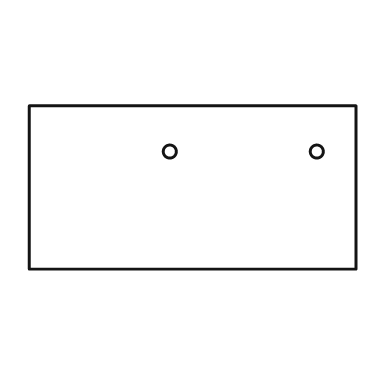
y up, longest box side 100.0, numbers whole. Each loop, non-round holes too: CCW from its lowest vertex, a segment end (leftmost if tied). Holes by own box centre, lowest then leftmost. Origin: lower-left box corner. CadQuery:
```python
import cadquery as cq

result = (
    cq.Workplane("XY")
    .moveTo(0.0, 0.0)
    .lineTo(100.0, 0.0)
    .lineTo(100.0, 50.0)
    .lineTo(0.0, 50.0)
    .close()
    .moveTo(43.0, 36.0)
    .circle(2.0)
    .moveTo(88.0, 36.0)
    .circle(2.0)
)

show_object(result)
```